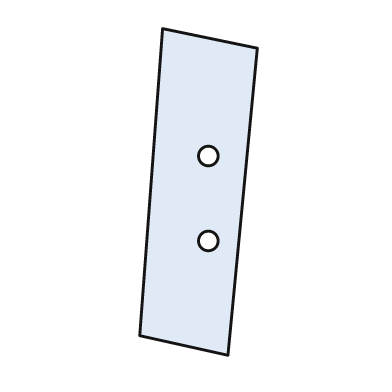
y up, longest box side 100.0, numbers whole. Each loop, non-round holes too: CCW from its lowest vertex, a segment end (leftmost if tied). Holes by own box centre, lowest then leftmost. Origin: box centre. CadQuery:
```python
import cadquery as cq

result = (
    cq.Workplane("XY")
    .moveTo(9.0, -50.0)
    .lineTo(18.0, 44.0)
    .lineTo(-11.0, 50.0)
    .lineTo(-18.0, -44.0)
    .close()
    .moveTo(3.0, -15.0)
    .circle(3.0)
    .moveTo(3.0, 11.0)
    .circle(3.0)
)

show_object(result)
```